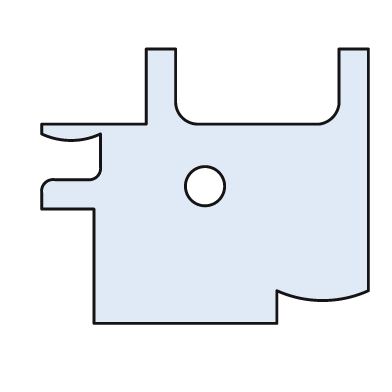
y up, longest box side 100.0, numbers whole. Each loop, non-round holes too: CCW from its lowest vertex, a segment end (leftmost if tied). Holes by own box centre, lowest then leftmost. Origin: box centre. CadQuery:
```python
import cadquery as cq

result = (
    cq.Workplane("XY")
    .moveTo(-34.0, -42.0)
    .lineTo(22.0, -42.0)
    .lineTo(22.0, -32.0)
    .threePointArc((36.0, -35.0), (50.0, -32.0))
    .lineTo(50.0, 42.0)
    .lineTo(41.0, 42.0)
    .lineTo(41.0, 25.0)
    .threePointArc((39.0, 21.0), (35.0, 19.0))
    .lineTo(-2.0, 19.0)
    .threePointArc((-7.0, 21.0), (-9.0, 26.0))
    .lineTo(-9.0, 42.0)
    .lineTo(-18.0, 42.0)
    .lineTo(-18.0, 19.0)
    .lineTo(-50.0, 19.0)
    .lineTo(-50.0, 16.0)
    .threePointArc((-41.0, 14.0), (-32.0, 16.0))
    .lineTo(-32.0, 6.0)
    .threePointArc((-33.0, 3.0), (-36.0, 2.0))
    .lineTo(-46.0, 2.0)
    .threePointArc((-49.0, 1.0), (-50.0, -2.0))
    .lineTo(-50.0, -7.0)
    .lineTo(-34.0, -7.0)
    .close()
    .moveTo(0.0, 0.0)
    .circle(6.0)
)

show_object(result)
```